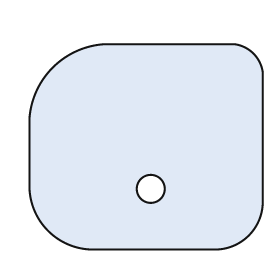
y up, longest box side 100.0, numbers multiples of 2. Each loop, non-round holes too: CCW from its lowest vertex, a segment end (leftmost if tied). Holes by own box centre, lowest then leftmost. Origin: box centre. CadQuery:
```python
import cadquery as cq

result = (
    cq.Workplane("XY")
    .moveTo(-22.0, -44.0)
    .lineTo(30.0, -44.0)
    .threePointArc((44.0, -38.0), (50.0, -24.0))
    .lineTo(50.0, 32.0)
    .threePointArc((46.0, 40.0), (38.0, 44.0))
    .lineTo(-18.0, 44.0)
    .threePointArc((-40.0, 34.0), (-50.0, 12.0))
    .lineTo(-50.0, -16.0)
    .threePointArc((-42.0, -36.0), (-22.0, -44.0))
    .close()
    .moveTo(2.0, -18.0)
    .circle(6.0)
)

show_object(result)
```